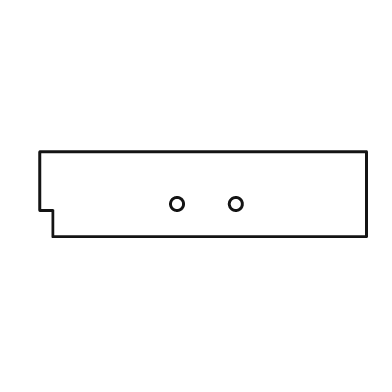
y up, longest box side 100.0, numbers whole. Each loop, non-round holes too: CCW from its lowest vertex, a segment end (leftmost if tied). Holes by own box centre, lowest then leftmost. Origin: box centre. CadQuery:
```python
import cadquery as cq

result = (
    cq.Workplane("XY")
    .moveTo(-46.0, -13.0)
    .lineTo(50.0, -13.0)
    .lineTo(50.0, 13.0)
    .lineTo(-50.0, 13.0)
    .lineTo(-50.0, -5.0)
    .lineTo(-46.0, -5.0)
    .close()
    .moveTo(-8.0, -3.0)
    .circle(2.0)
    .moveTo(10.0, -3.0)
    .circle(2.0)
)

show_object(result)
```